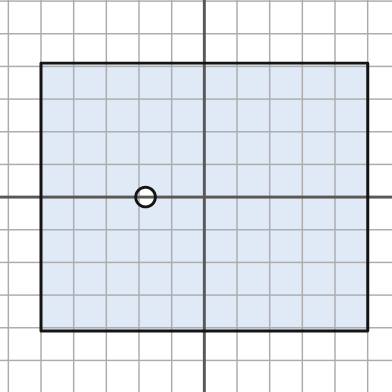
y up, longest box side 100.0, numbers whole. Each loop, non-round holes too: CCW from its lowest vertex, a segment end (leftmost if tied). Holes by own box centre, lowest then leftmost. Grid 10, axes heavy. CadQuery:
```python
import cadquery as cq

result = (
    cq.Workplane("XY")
    .moveTo(-50.0, -41.0)
    .lineTo(50.0, -41.0)
    .lineTo(50.0, 41.0)
    .lineTo(-50.0, 41.0)
    .close()
    .moveTo(-18.0, 0.0)
    .circle(3.0)
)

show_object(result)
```